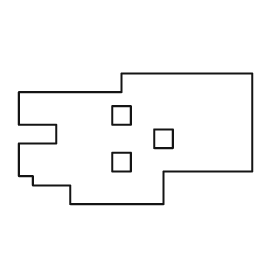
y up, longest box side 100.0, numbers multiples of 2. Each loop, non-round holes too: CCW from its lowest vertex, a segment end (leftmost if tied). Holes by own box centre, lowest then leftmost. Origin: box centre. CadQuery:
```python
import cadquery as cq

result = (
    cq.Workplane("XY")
    .moveTo(-28.0, -28.0)
    .lineTo(12.0, -28.0)
    .lineTo(12.0, -14.0)
    .lineTo(50.0, -14.0)
    .lineTo(50.0, 28.0)
    .lineTo(-6.0, 28.0)
    .lineTo(-6.0, 20.0)
    .lineTo(-50.0, 20.0)
    .lineTo(-50.0, 6.0)
    .lineTo(-34.0, 6.0)
    .lineTo(-34.0, -2.0)
    .lineTo(-50.0, -2.0)
    .lineTo(-50.0, -16.0)
    .lineTo(-44.0, -16.0)
    .lineTo(-44.0, -20.0)
    .lineTo(-28.0, -20.0)
    .close()
    .moveTo(-10.0, -14.0)
    .lineTo(-2.0, -14.0)
    .lineTo(-2.0, -6.0)
    .lineTo(-10.0, -6.0)
    .close()
    .moveTo(8.0, -4.0)
    .lineTo(16.0, -4.0)
    .lineTo(16.0, 4.0)
    .lineTo(8.0, 4.0)
    .close()
    .moveTo(-10.0, 6.0)
    .lineTo(-2.0, 6.0)
    .lineTo(-2.0, 14.0)
    .lineTo(-10.0, 14.0)
    .close()
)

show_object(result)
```